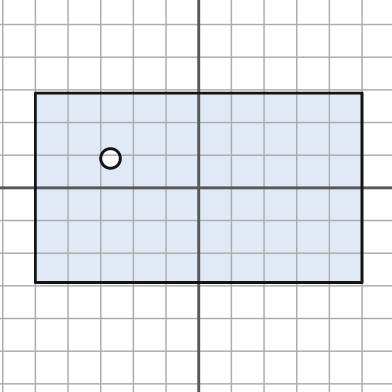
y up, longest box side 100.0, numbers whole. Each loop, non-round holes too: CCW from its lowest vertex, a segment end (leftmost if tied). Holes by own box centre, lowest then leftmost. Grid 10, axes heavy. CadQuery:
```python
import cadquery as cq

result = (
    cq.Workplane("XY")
    .moveTo(-50.0, -29.0)
    .lineTo(50.0, -29.0)
    .lineTo(50.0, 29.0)
    .lineTo(-50.0, 29.0)
    .close()
    .moveTo(-27.0, 9.0)
    .circle(3.0)
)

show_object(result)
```